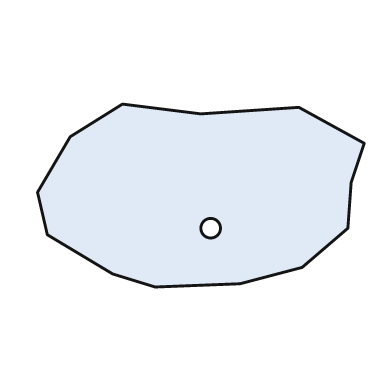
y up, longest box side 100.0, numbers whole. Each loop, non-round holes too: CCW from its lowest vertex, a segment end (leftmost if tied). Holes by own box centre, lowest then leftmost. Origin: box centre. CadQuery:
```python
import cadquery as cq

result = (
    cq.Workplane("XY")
    .moveTo(-14.0, -28.0)
    .lineTo(12.0, -27.0)
    .lineTo(31.0, -22.0)
    .lineTo(45.0, -10.0)
    .lineTo(46.0, 4.0)
    .lineTo(50.0, 16.0)
    .lineTo(30.0, 27.0)
    .lineTo(0.0, 25.0)
    .lineTo(-24.0, 28.0)
    .lineTo(-40.0, 18.0)
    .lineTo(-50.0, 1.0)
    .lineTo(-47.0, -12.0)
    .lineTo(-27.0, -24.0)
    .close()
    .moveTo(3.0, -10.0)
    .circle(3.0)
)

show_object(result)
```